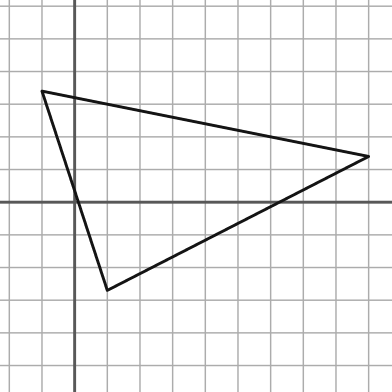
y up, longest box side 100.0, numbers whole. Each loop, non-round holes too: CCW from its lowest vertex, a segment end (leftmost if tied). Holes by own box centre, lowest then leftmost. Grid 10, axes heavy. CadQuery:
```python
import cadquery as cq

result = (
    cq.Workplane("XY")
    .moveTo(10.0, -27.0)
    .lineTo(90.0, 14.0)
    .lineTo(-10.0, 34.0)
    .close()
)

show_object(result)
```